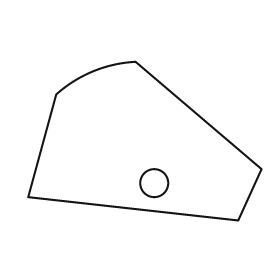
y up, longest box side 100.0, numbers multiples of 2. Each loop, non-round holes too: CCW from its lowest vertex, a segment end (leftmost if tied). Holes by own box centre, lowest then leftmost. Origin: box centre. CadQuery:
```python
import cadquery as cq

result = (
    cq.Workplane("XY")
    .moveTo(40.0, -34.0)
    .lineTo(50.0, -12.0)
    .lineTo(-4.0, 34.0)
    .threePointArc((-22.0, 30.0), (-38.0, 20.0))
    .lineTo(-50.0, -24.0)
    .close()
    .moveTo(4.0, -18.0)
    .circle(6.0)
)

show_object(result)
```